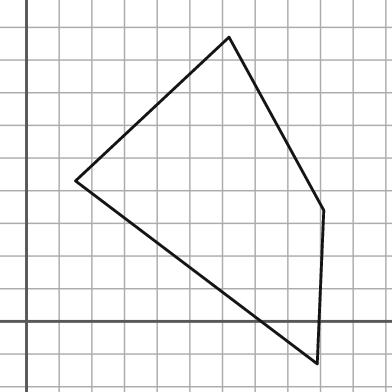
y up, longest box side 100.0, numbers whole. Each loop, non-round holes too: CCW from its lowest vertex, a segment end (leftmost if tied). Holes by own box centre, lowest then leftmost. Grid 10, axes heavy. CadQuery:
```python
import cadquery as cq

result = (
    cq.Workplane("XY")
    .moveTo(89.0, -13.0)
    .lineTo(91.0, 34.0)
    .lineTo(62.0, 87.0)
    .lineTo(15.0, 43.0)
    .close()
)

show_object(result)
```